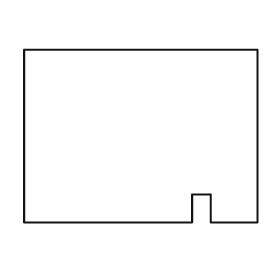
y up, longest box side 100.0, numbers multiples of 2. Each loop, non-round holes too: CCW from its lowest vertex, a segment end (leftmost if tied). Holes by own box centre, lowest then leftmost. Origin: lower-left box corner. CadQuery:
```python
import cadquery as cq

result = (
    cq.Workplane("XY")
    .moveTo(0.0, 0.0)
    .lineTo(72.0, 0.0)
    .lineTo(72.0, 12.0)
    .lineTo(80.0, 12.0)
    .lineTo(80.0, 0.0)
    .lineTo(100.0, 0.0)
    .lineTo(100.0, 74.0)
    .lineTo(0.0, 74.0)
    .close()
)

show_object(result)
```